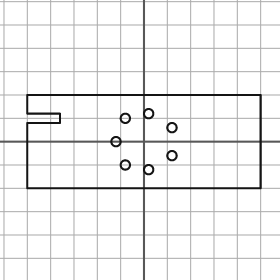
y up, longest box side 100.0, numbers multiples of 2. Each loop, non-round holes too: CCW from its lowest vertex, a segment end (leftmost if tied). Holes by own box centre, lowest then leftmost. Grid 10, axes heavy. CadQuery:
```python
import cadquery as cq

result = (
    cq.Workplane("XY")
    .moveTo(-50.0, -20.0)
    .lineTo(50.0, -20.0)
    .lineTo(50.0, 20.0)
    .lineTo(-50.0, 20.0)
    .lineTo(-50.0, 12.0)
    .lineTo(-36.0, 12.0)
    .lineTo(-36.0, 8.0)
    .lineTo(-50.0, 8.0)
    .close()
    .moveTo(2.0, -12.0)
    .circle(2.0)
    .moveTo(-8.0, -10.0)
    .circle(2.0)
    .moveTo(12.0, -6.0)
    .circle(2.0)
    .moveTo(-12.0, 0.0)
    .circle(2.0)
    .moveTo(12.0, 6.0)
    .circle(2.0)
    .moveTo(-8.0, 10.0)
    .circle(2.0)
    .moveTo(2.0, 12.0)
    .circle(2.0)
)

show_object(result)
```